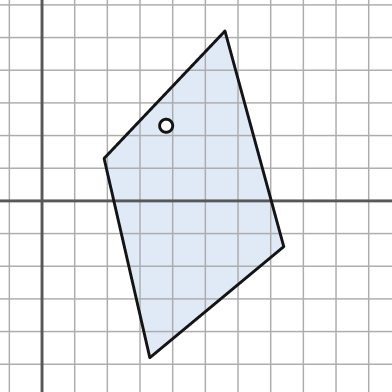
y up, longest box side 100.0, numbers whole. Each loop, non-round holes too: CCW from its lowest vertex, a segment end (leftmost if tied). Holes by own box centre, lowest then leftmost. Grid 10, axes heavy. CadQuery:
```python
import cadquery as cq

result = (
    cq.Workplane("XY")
    .moveTo(33.0, -48.0)
    .lineTo(74.0, -14.0)
    .lineTo(56.0, 52.0)
    .lineTo(19.0, 13.0)
    .close()
    .moveTo(38.0, 23.0)
    .circle(2.0)
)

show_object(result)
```